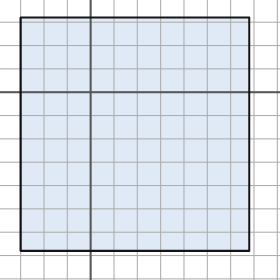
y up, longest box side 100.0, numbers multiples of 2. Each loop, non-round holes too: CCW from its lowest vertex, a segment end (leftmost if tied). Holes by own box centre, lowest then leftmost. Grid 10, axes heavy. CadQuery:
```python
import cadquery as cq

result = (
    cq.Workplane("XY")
    .moveTo(-30.0, -68.0)
    .lineTo(68.0, -68.0)
    .lineTo(68.0, 32.0)
    .lineTo(-30.0, 32.0)
    .close()
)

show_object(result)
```